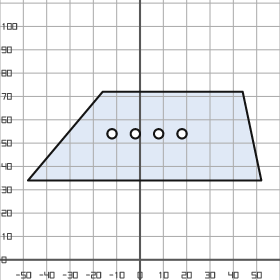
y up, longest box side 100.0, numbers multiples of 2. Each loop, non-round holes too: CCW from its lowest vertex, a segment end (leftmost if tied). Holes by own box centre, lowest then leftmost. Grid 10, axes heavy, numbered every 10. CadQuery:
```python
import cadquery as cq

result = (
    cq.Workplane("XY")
    .moveTo(-48.0, 34.0)
    .lineTo(52.0, 34.0)
    .lineTo(44.0, 72.0)
    .lineTo(-16.0, 72.0)
    .close()
    .moveTo(-12.0, 54.0)
    .circle(2.0)
    .moveTo(-2.0, 54.0)
    .circle(2.0)
    .moveTo(8.0, 54.0)
    .circle(2.0)
    .moveTo(18.0, 54.0)
    .circle(2.0)
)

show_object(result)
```